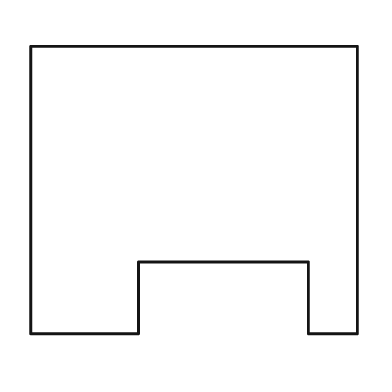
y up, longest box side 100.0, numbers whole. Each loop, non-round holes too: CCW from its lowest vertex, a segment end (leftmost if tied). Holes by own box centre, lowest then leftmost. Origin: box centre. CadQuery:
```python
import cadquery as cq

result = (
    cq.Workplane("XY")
    .moveTo(-50.0, -44.0)
    .lineTo(-17.0, -44.0)
    .lineTo(-17.0, -22.0)
    .lineTo(35.0, -22.0)
    .lineTo(35.0, -44.0)
    .lineTo(50.0, -44.0)
    .lineTo(50.0, 44.0)
    .lineTo(-50.0, 44.0)
    .close()
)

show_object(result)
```